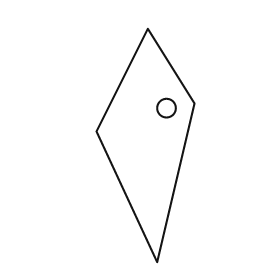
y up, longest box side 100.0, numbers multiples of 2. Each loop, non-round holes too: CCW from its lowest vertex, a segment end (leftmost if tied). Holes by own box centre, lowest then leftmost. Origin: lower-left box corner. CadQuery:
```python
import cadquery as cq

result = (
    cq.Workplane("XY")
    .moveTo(26.0, 0.0)
    .lineTo(42.0, 68.0)
    .lineTo(22.0, 100.0)
    .lineTo(0.0, 56.0)
    .close()
    .moveTo(30.0, 66.0)
    .circle(4.0)
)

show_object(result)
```